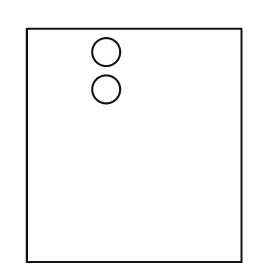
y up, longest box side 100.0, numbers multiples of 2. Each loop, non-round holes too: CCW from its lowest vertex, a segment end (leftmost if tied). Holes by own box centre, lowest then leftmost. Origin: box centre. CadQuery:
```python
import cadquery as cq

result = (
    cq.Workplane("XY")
    .moveTo(-46.0, -50.0)
    .lineTo(46.0, -50.0)
    .lineTo(46.0, 50.0)
    .lineTo(-46.0, 50.0)
    .close()
    .moveTo(-12.0, 24.0)
    .circle(6.0)
    .moveTo(-12.0, 40.0)
    .circle(6.0)
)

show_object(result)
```